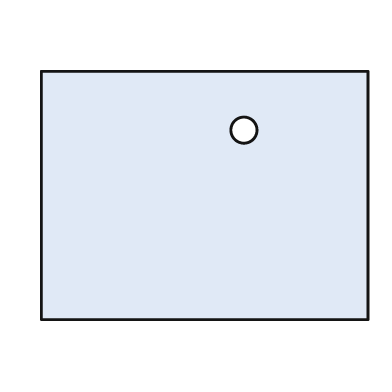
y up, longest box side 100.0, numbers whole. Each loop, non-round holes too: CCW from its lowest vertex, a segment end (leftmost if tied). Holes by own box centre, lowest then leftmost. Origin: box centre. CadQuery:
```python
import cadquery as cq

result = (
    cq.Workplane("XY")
    .moveTo(-50.0, -38.0)
    .lineTo(50.0, -38.0)
    .lineTo(50.0, 38.0)
    .lineTo(-50.0, 38.0)
    .close()
    .moveTo(12.0, 20.0)
    .circle(4.0)
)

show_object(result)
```